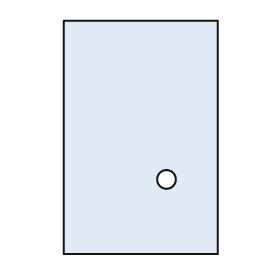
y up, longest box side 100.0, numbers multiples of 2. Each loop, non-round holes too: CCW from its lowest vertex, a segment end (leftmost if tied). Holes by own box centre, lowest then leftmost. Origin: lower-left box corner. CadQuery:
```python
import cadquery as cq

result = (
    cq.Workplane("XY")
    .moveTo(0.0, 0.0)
    .lineTo(66.0, 0.0)
    .lineTo(66.0, 100.0)
    .lineTo(0.0, 100.0)
    .close()
    .moveTo(44.0, 32.0)
    .circle(4.0)
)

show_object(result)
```